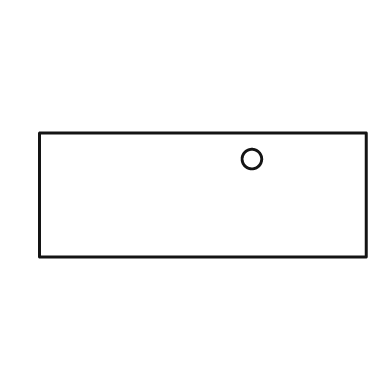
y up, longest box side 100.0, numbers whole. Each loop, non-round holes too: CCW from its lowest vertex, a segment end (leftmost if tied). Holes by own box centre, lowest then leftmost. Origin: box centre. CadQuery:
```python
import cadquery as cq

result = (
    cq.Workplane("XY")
    .moveTo(-50.0, -19.0)
    .lineTo(50.0, -19.0)
    .lineTo(50.0, 19.0)
    .lineTo(-50.0, 19.0)
    .close()
    .moveTo(15.0, 11.0)
    .circle(3.0)
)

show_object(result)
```